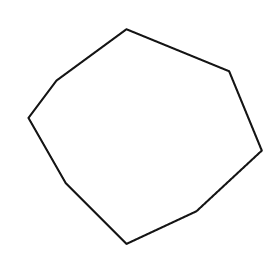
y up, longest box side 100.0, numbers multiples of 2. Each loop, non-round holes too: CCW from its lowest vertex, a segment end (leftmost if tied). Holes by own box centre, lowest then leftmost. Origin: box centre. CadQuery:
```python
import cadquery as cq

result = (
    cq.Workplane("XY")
    .moveTo(-8.0, -46.0)
    .lineTo(22.0, -32.0)
    .lineTo(50.0, -6.0)
    .lineTo(36.0, 28.0)
    .lineTo(-8.0, 46.0)
    .lineTo(-38.0, 24.0)
    .lineTo(-50.0, 8.0)
    .lineTo(-34.0, -20.0)
    .close()
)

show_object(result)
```